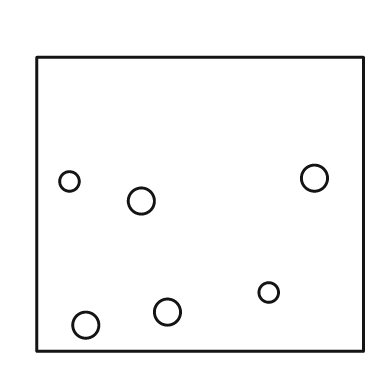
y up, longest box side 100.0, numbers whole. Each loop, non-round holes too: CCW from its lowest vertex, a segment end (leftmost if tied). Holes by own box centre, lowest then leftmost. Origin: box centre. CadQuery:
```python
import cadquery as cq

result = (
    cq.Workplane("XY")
    .moveTo(-50.0, -45.0)
    .lineTo(50.0, -45.0)
    .lineTo(50.0, 45.0)
    .lineTo(-50.0, 45.0)
    .close()
    .moveTo(-35.0, -37.0)
    .circle(4.0)
    .moveTo(-10.0, -33.0)
    .circle(4.0)
    .moveTo(21.0, -27.0)
    .circle(3.0)
    .moveTo(-18.0, 1.0)
    .circle(4.0)
    .moveTo(-40.0, 7.0)
    .circle(3.0)
    .moveTo(35.0, 8.0)
    .circle(4.0)
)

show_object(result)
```